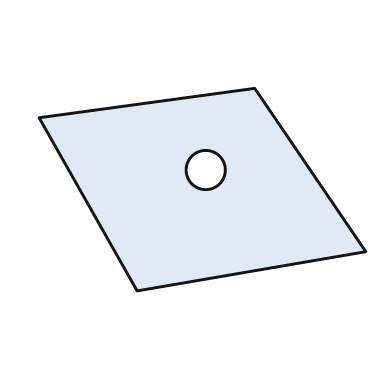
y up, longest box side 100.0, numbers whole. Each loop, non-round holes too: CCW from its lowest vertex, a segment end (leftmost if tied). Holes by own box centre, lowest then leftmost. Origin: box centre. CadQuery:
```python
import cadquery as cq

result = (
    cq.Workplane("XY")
    .moveTo(-20.0, -31.0)
    .lineTo(50.0, -19.0)
    .lineTo(16.0, 31.0)
    .lineTo(-50.0, 22.0)
    .close()
    .moveTo(1.0, 6.0)
    .circle(6.0)
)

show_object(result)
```